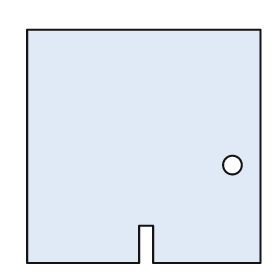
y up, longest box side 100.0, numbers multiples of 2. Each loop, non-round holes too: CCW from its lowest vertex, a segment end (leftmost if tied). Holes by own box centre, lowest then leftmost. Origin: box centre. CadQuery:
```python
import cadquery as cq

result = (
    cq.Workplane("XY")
    .moveTo(-50.0, -50.0)
    .lineTo(-2.0, -50.0)
    .lineTo(-2.0, -34.0)
    .lineTo(4.0, -34.0)
    .lineTo(4.0, -50.0)
    .lineTo(50.0, -50.0)
    .lineTo(50.0, 50.0)
    .lineTo(-50.0, 50.0)
    .close()
    .moveTo(38.0, -8.0)
    .circle(4.0)
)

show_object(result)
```